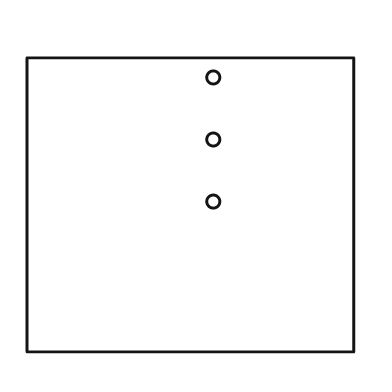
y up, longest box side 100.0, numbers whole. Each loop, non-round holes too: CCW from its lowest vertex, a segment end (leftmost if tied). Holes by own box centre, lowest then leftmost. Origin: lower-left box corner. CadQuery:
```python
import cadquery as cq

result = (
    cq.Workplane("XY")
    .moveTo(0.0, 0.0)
    .lineTo(100.0, 0.0)
    .lineTo(100.0, 90.0)
    .lineTo(0.0, 90.0)
    .close()
    .moveTo(57.0, 46.0)
    .circle(2.0)
    .moveTo(57.0, 65.0)
    .circle(2.0)
    .moveTo(57.0, 84.0)
    .circle(2.0)
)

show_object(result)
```